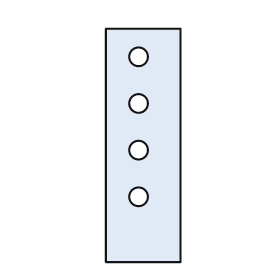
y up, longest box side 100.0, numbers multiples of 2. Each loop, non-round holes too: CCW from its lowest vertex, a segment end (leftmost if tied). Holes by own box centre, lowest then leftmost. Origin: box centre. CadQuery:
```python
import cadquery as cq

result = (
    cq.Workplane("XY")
    .moveTo(-16.0, -50.0)
    .lineTo(16.0, -50.0)
    .lineTo(16.0, 50.0)
    .lineTo(-16.0, 50.0)
    .close()
    .moveTo(-2.0, -22.0)
    .circle(4.0)
    .moveTo(-2.0, -2.0)
    .circle(4.0)
    .moveTo(-2.0, 18.0)
    .circle(4.0)
    .moveTo(-2.0, 38.0)
    .circle(4.0)
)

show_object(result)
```